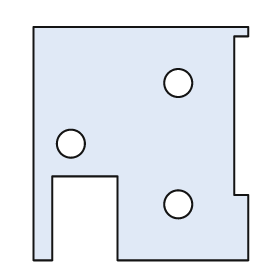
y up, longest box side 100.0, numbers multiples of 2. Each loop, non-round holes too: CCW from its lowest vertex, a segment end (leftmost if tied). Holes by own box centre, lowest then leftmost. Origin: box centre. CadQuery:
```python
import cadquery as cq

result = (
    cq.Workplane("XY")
    .moveTo(-46.0, -50.0)
    .lineTo(-38.0, -50.0)
    .lineTo(-38.0, -14.0)
    .lineTo(-10.0, -14.0)
    .lineTo(-10.0, -50.0)
    .lineTo(46.0, -50.0)
    .lineTo(46.0, -22.0)
    .lineTo(40.0, -22.0)
    .lineTo(40.0, 46.0)
    .lineTo(46.0, 46.0)
    .lineTo(46.0, 50.0)
    .lineTo(-46.0, 50.0)
    .close()
    .moveTo(16.0, -26.0)
    .circle(6.0)
    .moveTo(-30.0, 0.0)
    .circle(6.0)
    .moveTo(16.0, 26.0)
    .circle(6.0)
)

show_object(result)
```